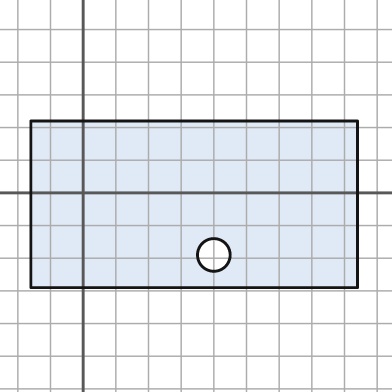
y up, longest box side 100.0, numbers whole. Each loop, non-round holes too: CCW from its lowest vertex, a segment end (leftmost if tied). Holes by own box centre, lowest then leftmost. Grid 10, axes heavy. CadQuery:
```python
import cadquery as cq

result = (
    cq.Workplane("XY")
    .moveTo(-16.0, -29.0)
    .lineTo(84.0, -29.0)
    .lineTo(84.0, 22.0)
    .lineTo(-16.0, 22.0)
    .close()
    .moveTo(40.0, -19.0)
    .circle(5.0)
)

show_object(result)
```